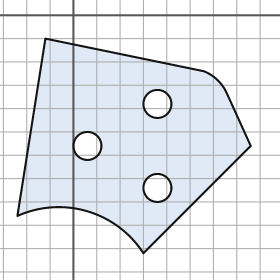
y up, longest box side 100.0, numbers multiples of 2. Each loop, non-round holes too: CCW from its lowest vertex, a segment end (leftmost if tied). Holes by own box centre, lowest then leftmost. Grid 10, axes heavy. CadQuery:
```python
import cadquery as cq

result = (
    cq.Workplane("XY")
    .moveTo(30.0, -102.0)
    .lineTo(76.0, -56.0)
    .lineTo(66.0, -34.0)
    .threePointArc((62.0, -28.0), (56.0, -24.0))
    .lineTo(-12.0, -10.0)
    .lineTo(-24.0, -86.0)
    .threePointArc((6.0, -84.0), (30.0, -102.0))
    .close()
    .moveTo(36.0, -74.0)
    .circle(6.0)
    .moveTo(6.0, -56.0)
    .circle(6.0)
    .moveTo(36.0, -38.0)
    .circle(6.0)
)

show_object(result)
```